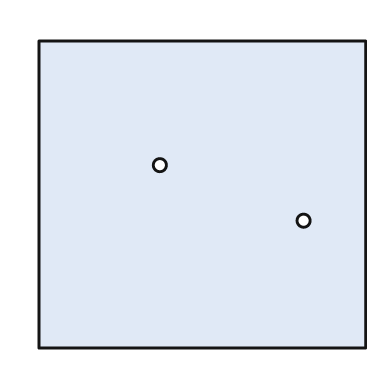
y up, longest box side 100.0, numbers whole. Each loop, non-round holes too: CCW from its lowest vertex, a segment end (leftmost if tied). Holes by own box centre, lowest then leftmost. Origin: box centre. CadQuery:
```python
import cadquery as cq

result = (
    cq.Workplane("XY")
    .moveTo(-50.0, -47.0)
    .lineTo(50.0, -47.0)
    .lineTo(50.0, 47.0)
    .lineTo(-50.0, 47.0)
    .close()
    .moveTo(31.0, -8.0)
    .circle(2.0)
    .moveTo(-13.0, 9.0)
    .circle(2.0)
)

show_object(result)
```